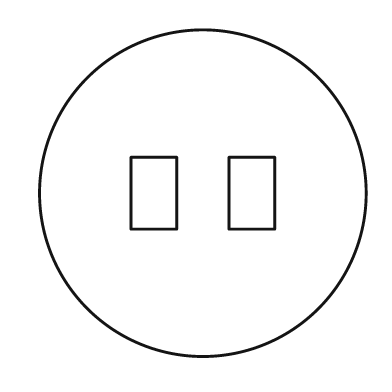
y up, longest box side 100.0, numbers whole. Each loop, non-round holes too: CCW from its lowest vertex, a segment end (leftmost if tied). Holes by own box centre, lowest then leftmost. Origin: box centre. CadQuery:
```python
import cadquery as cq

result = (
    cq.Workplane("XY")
    .moveTo(0.0, 0.0)
    .circle(50.0)
    .moveTo(-22.0, -11.0)
    .lineTo(-8.0, -11.0)
    .lineTo(-8.0, 11.0)
    .lineTo(-22.0, 11.0)
    .close()
    .moveTo(8.0, -11.0)
    .lineTo(22.0, -11.0)
    .lineTo(22.0, 11.0)
    .lineTo(8.0, 11.0)
    .close()
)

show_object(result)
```